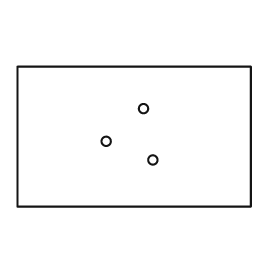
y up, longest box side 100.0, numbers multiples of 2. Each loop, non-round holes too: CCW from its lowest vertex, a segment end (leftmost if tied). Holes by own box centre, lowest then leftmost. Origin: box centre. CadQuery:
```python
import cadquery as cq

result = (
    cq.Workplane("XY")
    .moveTo(-50.0, -30.0)
    .lineTo(50.0, -30.0)
    .lineTo(50.0, 30.0)
    .lineTo(-50.0, 30.0)
    .close()
    .moveTo(8.0, -10.0)
    .circle(2.0)
    .moveTo(-12.0, -2.0)
    .circle(2.0)
    .moveTo(4.0, 12.0)
    .circle(2.0)
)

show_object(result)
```